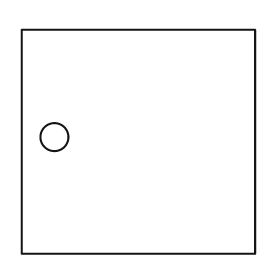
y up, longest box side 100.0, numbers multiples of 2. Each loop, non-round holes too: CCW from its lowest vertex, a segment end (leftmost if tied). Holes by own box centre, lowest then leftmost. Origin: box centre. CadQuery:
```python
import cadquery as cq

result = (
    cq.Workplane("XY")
    .moveTo(-50.0, -48.0)
    .lineTo(50.0, -48.0)
    .lineTo(50.0, 48.0)
    .lineTo(-50.0, 48.0)
    .close()
    .moveTo(-36.0, 2.0)
    .circle(6.0)
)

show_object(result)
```